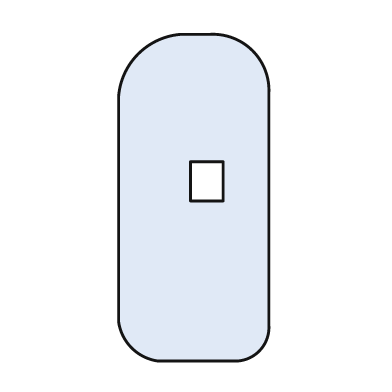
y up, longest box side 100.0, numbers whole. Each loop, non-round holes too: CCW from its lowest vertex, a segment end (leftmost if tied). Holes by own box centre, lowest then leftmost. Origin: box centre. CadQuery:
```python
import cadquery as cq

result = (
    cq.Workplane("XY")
    .moveTo(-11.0, -50.0)
    .lineTo(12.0, -50.0)
    .threePointArc((20.0, -47.0), (23.0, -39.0))
    .lineTo(23.0, 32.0)
    .threePointArc((18.0, 45.0), (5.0, 50.0))
    .lineTo(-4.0, 50.0)
    .threePointArc((-17.0, 44.0), (-23.0, 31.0))
    .lineTo(-23.0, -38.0)
    .threePointArc((-19.0, -46.0), (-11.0, -50.0))
    .close()
    .moveTo(-1.0, -1.0)
    .lineTo(9.0, -1.0)
    .lineTo(9.0, 11.0)
    .lineTo(-1.0, 11.0)
    .close()
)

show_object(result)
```